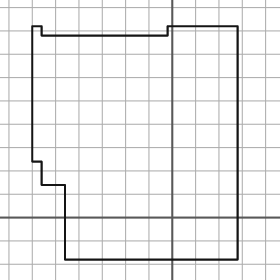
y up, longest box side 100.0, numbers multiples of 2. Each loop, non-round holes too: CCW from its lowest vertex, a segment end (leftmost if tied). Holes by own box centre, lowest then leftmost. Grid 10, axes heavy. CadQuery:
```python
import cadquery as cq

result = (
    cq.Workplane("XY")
    .moveTo(-46.0, -18.0)
    .lineTo(28.0, -18.0)
    .lineTo(28.0, 82.0)
    .lineTo(-2.0, 82.0)
    .lineTo(-2.0, 78.0)
    .lineTo(-56.0, 78.0)
    .lineTo(-56.0, 82.0)
    .lineTo(-60.0, 82.0)
    .lineTo(-60.0, 24.0)
    .lineTo(-56.0, 24.0)
    .lineTo(-56.0, 14.0)
    .lineTo(-46.0, 14.0)
    .close()
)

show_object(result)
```